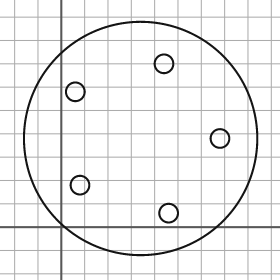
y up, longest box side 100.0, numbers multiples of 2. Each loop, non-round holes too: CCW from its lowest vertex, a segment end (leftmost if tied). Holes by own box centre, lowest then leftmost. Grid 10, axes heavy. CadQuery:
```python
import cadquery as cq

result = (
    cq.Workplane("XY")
    .moveTo(34.0, 38.0)
    .circle(50.0)
    .moveTo(46.0, 6.0)
    .circle(4.0)
    .moveTo(8.0, 18.0)
    .circle(4.0)
    .moveTo(68.0, 38.0)
    .circle(4.0)
    .moveTo(6.0, 58.0)
    .circle(4.0)
    .moveTo(44.0, 70.0)
    .circle(4.0)
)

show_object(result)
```